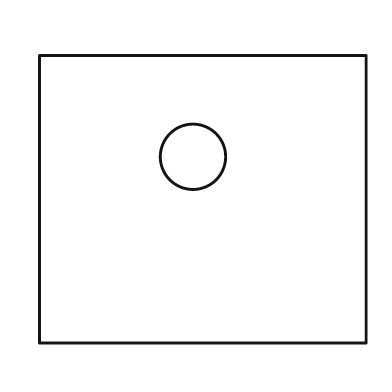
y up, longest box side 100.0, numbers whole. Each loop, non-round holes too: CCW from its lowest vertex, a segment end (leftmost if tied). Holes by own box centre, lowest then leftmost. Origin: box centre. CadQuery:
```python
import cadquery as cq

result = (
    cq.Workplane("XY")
    .moveTo(-50.0, -44.0)
    .lineTo(50.0, -44.0)
    .lineTo(50.0, 44.0)
    .lineTo(-50.0, 44.0)
    .close()
    .moveTo(-3.0, 13.0)
    .circle(10.0)
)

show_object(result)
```